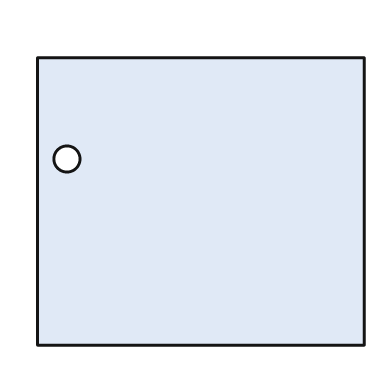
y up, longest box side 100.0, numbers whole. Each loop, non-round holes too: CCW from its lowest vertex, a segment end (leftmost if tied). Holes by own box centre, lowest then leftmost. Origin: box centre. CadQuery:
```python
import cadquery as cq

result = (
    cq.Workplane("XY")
    .moveTo(-50.0, -44.0)
    .lineTo(50.0, -44.0)
    .lineTo(50.0, 44.0)
    .lineTo(-50.0, 44.0)
    .close()
    .moveTo(-41.0, 13.0)
    .circle(4.0)
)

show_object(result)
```